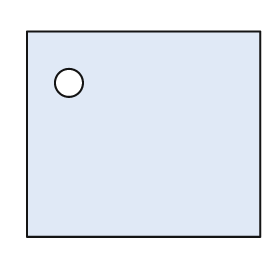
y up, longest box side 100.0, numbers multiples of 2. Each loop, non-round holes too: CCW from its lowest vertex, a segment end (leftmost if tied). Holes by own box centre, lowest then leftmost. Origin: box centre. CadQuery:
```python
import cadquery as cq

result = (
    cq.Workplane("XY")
    .moveTo(-50.0, -44.0)
    .lineTo(50.0, -44.0)
    .lineTo(50.0, 44.0)
    .lineTo(-50.0, 44.0)
    .close()
    .moveTo(-32.0, 22.0)
    .circle(6.0)
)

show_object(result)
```